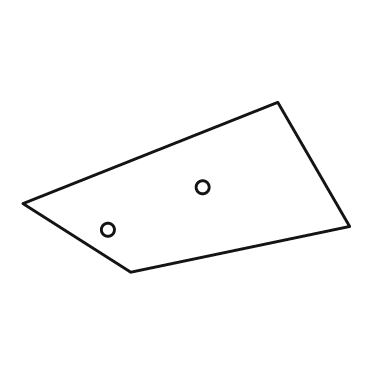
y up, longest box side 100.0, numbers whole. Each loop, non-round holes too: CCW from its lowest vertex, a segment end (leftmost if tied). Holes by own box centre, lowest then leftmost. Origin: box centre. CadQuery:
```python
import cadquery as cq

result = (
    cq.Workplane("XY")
    .moveTo(-17.0, -26.0)
    .lineTo(50.0, -12.0)
    .lineTo(28.0, 26.0)
    .lineTo(-50.0, -5.0)
    .close()
    .moveTo(-24.0, -13.0)
    .circle(2.0)
    .moveTo(5.0, 0.0)
    .circle(2.0)
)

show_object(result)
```